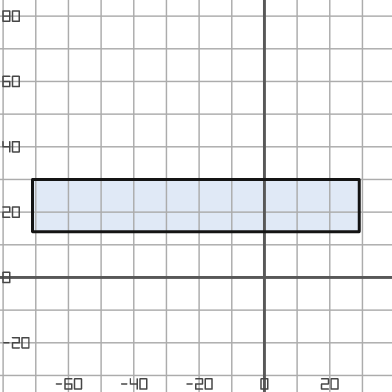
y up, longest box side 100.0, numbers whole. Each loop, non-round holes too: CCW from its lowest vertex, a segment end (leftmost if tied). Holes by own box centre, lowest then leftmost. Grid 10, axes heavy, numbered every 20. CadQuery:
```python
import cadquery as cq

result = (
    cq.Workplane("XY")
    .moveTo(-71.0, 14.0)
    .lineTo(29.0, 14.0)
    .lineTo(29.0, 30.0)
    .lineTo(-71.0, 30.0)
    .close()
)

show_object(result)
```